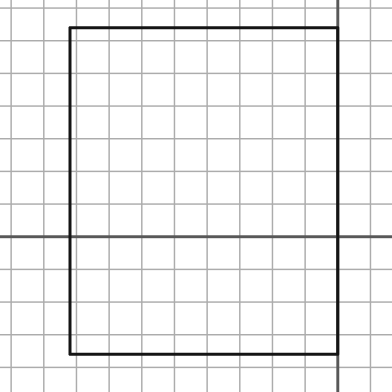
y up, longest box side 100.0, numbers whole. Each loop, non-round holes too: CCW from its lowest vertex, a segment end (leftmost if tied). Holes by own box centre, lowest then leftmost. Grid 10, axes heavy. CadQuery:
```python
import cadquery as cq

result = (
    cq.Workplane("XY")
    .moveTo(-82.0, -36.0)
    .lineTo(0.0, -36.0)
    .lineTo(0.0, 64.0)
    .lineTo(-82.0, 64.0)
    .close()
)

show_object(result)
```